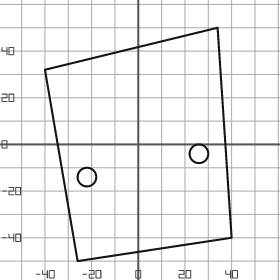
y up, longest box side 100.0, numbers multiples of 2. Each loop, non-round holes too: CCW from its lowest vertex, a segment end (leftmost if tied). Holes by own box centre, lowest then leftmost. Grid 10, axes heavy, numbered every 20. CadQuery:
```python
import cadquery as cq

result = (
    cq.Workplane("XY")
    .moveTo(-26.0, -50.0)
    .lineTo(40.0, -40.0)
    .lineTo(34.0, 50.0)
    .lineTo(-40.0, 32.0)
    .close()
    .moveTo(-22.0, -14.0)
    .circle(4.0)
    .moveTo(26.0, -4.0)
    .circle(4.0)
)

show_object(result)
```